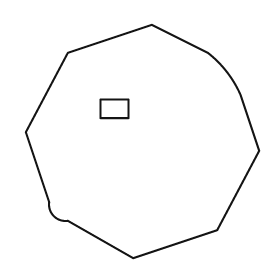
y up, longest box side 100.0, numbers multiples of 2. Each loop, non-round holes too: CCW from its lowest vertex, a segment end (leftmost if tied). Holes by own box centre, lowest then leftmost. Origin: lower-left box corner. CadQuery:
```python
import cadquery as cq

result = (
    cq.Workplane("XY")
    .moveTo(46.0, 0.0)
    .lineTo(82.0, 12.0)
    .lineTo(100.0, 46.0)
    .lineTo(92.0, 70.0)
    .threePointArc((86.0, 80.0), (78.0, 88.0))
    .lineTo(54.0, 100.0)
    .lineTo(18.0, 88.0)
    .lineTo(0.0, 54.0)
    .lineTo(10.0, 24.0)
    .threePointArc((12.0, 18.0), (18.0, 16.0))
    .close()
    .moveTo(32.0, 60.0)
    .lineTo(44.0, 60.0)
    .lineTo(44.0, 68.0)
    .lineTo(32.0, 68.0)
    .close()
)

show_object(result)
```